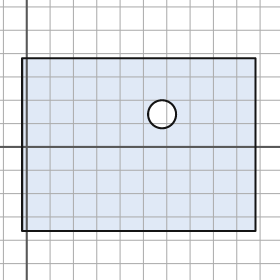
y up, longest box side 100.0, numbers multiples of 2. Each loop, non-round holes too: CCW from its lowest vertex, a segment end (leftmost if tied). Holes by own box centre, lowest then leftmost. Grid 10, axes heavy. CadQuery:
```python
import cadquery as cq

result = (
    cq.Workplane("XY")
    .moveTo(-2.0, -36.0)
    .lineTo(98.0, -36.0)
    .lineTo(98.0, 38.0)
    .lineTo(-2.0, 38.0)
    .close()
    .moveTo(58.0, 14.0)
    .circle(6.0)
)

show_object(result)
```